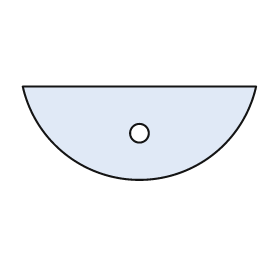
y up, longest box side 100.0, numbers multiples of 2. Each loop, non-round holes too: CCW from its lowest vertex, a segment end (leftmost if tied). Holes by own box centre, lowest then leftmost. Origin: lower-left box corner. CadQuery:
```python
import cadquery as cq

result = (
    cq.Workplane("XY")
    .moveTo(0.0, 40.0)
    .threePointArc((50.0, 0.0), (100.0, 40.0))
    .close()
    .moveTo(50.0, 20.0)
    .circle(4.0)
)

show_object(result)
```